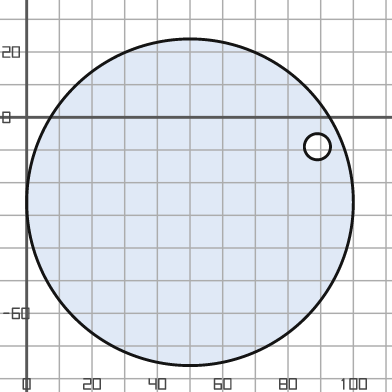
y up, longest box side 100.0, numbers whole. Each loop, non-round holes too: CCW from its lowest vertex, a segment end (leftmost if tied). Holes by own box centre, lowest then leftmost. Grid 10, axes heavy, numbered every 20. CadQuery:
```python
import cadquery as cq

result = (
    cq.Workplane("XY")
    .moveTo(50.0, -26.0)
    .circle(50.0)
    .moveTo(89.0, -9.0)
    .circle(4.0)
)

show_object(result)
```